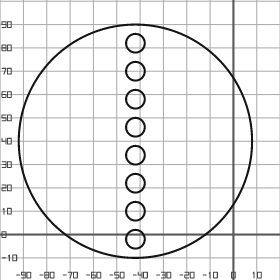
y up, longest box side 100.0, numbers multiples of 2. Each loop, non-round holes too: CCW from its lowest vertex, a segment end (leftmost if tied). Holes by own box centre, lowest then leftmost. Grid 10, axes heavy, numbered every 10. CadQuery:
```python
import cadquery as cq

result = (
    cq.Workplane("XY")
    .moveTo(-42.0, 40.0)
    .circle(50.0)
    .moveTo(-42.0, -2.0)
    .circle(4.0)
    .moveTo(-42.0, 10.0)
    .circle(4.0)
    .moveTo(-42.0, 22.0)
    .circle(4.0)
    .moveTo(-42.0, 34.0)
    .circle(4.0)
    .moveTo(-42.0, 46.0)
    .circle(4.0)
    .moveTo(-42.0, 58.0)
    .circle(4.0)
    .moveTo(-42.0, 70.0)
    .circle(4.0)
    .moveTo(-42.0, 82.0)
    .circle(4.0)
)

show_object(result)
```